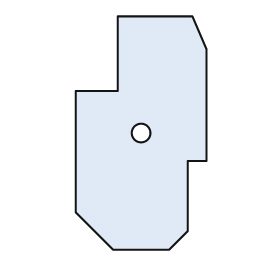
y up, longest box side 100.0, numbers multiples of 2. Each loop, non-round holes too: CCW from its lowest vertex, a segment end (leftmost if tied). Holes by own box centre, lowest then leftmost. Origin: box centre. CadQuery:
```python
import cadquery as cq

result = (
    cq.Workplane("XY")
    .moveTo(-12.0, -50.0)
    .lineTo(12.0, -50.0)
    .lineTo(20.0, -42.0)
    .lineTo(20.0, -12.0)
    .lineTo(28.0, -12.0)
    .lineTo(28.0, 36.0)
    .lineTo(22.0, 50.0)
    .lineTo(-10.0, 50.0)
    .lineTo(-10.0, 18.0)
    .lineTo(-28.0, 18.0)
    .lineTo(-28.0, -34.0)
    .close()
    .moveTo(0.0, 0.0)
    .circle(4.0)
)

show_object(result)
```